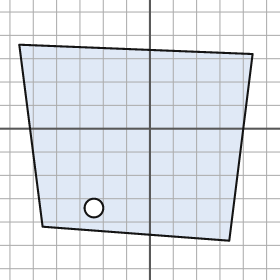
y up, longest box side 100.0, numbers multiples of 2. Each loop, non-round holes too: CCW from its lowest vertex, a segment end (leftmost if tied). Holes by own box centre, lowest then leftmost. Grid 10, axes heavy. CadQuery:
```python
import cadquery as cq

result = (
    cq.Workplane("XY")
    .moveTo(34.0, -48.0)
    .lineTo(44.0, 32.0)
    .lineTo(-56.0, 36.0)
    .lineTo(-46.0, -42.0)
    .close()
    .moveTo(-24.0, -34.0)
    .circle(4.0)
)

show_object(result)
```